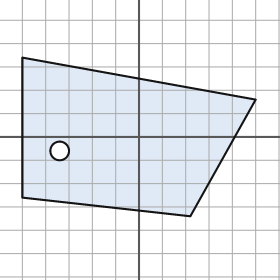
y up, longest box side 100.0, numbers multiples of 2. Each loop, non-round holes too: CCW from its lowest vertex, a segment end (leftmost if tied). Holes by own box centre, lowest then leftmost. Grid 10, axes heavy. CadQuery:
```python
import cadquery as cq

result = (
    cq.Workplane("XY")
    .moveTo(22.0, -34.0)
    .lineTo(50.0, 16.0)
    .lineTo(-50.0, 34.0)
    .lineTo(-50.0, -26.0)
    .close()
    .moveTo(-34.0, -6.0)
    .circle(4.0)
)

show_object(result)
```